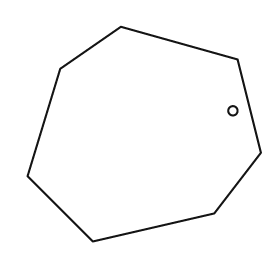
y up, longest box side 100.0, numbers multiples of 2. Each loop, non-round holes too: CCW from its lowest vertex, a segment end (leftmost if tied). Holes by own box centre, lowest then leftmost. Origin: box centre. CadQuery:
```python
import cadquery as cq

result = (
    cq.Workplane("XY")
    .moveTo(-22.0, -46.0)
    .lineTo(30.0, -34.0)
    .lineTo(50.0, -8.0)
    .lineTo(40.0, 32.0)
    .lineTo(-10.0, 46.0)
    .lineTo(-36.0, 28.0)
    .lineTo(-50.0, -18.0)
    .close()
    .moveTo(38.0, 10.0)
    .circle(2.0)
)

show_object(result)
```